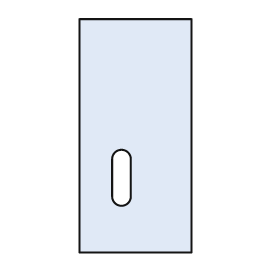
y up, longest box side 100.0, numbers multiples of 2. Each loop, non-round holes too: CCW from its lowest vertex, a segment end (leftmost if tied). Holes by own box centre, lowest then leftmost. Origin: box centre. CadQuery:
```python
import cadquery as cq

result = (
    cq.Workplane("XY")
    .moveTo(-24.0, -50.0)
    .lineTo(24.0, -50.0)
    .lineTo(24.0, 50.0)
    .lineTo(-24.0, 50.0)
    .close()
    .moveTo(-10.0, -26.0)
    .threePointArc((-6.0, -30.0), (-2.0, -26.0))
    .lineTo(-2.0, -10.0)
    .threePointArc((-6.0, -6.0), (-10.0, -10.0))
    .close()
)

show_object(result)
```